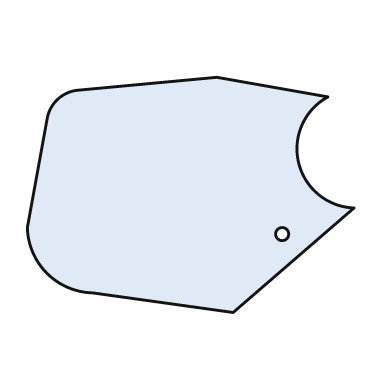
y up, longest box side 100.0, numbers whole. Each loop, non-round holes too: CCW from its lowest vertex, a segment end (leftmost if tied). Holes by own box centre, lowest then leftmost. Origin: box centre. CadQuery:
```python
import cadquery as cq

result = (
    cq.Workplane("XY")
    .moveTo(13.0, -36.0)
    .lineTo(50.0, -4.0)
    .threePointArc((33.0, 10.0), (42.0, 30.0))
    .lineTo(8.0, 36.0)
    .lineTo(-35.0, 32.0)
    .threePointArc((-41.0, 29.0), (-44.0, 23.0))
    .lineTo(-50.0, -10.0)
    .threePointArc((-44.0, -24.0), (-30.0, -30.0))
    .close()
    .moveTo(28.0, -12.0)
    .circle(2.0)
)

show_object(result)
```